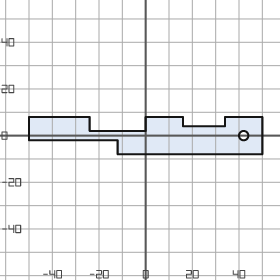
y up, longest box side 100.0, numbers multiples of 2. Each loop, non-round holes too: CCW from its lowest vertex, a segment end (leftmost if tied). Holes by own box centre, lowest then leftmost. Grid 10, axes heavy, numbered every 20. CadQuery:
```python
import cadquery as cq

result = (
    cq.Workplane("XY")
    .moveTo(-12.0, -8.0)
    .lineTo(50.0, -8.0)
    .lineTo(50.0, 8.0)
    .lineTo(34.0, 8.0)
    .lineTo(34.0, 4.0)
    .lineTo(16.0, 4.0)
    .lineTo(16.0, 8.0)
    .lineTo(0.0, 8.0)
    .lineTo(0.0, 2.0)
    .lineTo(-24.0, 2.0)
    .lineTo(-24.0, 8.0)
    .lineTo(-50.0, 8.0)
    .lineTo(-50.0, -2.0)
    .lineTo(-12.0, -2.0)
    .close()
    .moveTo(42.0, 0.0)
    .circle(2.0)
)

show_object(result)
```